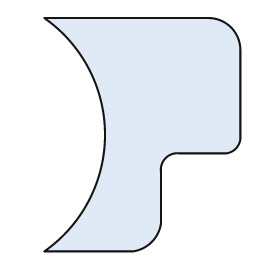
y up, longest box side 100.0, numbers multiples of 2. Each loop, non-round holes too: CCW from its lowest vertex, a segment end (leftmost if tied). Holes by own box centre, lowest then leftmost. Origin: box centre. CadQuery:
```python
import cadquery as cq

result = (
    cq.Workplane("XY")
    .moveTo(-42.0, -50.0)
    .lineTo(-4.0, -50.0)
    .threePointArc((4.0, -46.0), (8.0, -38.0))
    .lineTo(8.0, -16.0)
    .threePointArc((10.0, -10.0), (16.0, -8.0))
    .lineTo(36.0, -8.0)
    .threePointArc((40.0, -6.0), (42.0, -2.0))
    .lineTo(42.0, 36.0)
    .threePointArc((38.0, 46.0), (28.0, 50.0))
    .lineTo(-42.0, 50.0)
    .threePointArc((-16.0, 0.0), (-42.0, -50.0))
    .close()
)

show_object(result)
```